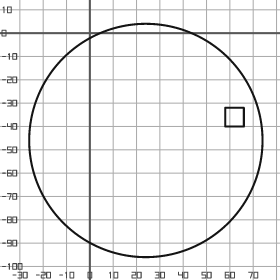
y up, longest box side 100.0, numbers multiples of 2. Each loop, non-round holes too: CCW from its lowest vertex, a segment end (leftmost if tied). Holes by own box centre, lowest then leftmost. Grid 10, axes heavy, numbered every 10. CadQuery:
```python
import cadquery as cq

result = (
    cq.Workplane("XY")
    .moveTo(24.0, -46.0)
    .circle(50.0)
    .moveTo(58.0, -40.0)
    .lineTo(66.0, -40.0)
    .lineTo(66.0, -32.0)
    .lineTo(58.0, -32.0)
    .close()
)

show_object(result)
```